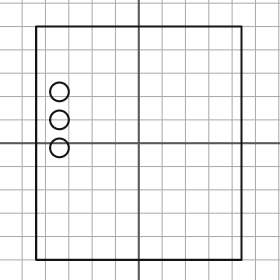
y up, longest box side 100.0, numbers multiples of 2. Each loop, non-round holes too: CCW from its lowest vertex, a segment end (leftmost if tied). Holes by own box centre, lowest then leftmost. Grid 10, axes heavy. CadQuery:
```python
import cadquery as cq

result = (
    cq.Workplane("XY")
    .moveTo(-44.0, -50.0)
    .lineTo(44.0, -50.0)
    .lineTo(44.0, 50.0)
    .lineTo(-44.0, 50.0)
    .close()
    .moveTo(-34.0, -2.0)
    .circle(4.0)
    .moveTo(-34.0, 10.0)
    .circle(4.0)
    .moveTo(-34.0, 22.0)
    .circle(4.0)
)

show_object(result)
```